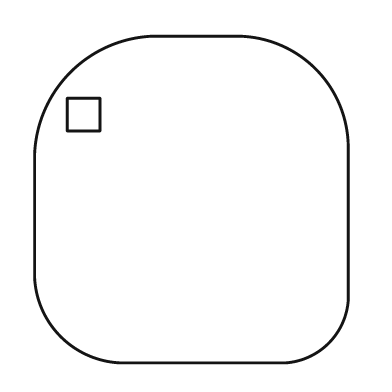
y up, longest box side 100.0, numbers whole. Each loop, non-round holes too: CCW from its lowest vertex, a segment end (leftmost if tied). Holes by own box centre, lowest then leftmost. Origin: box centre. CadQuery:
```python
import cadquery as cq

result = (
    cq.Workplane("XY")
    .moveTo(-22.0, -50.0)
    .lineTo(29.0, -50.0)
    .threePointArc((42.0, -44.0), (48.0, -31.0))
    .lineTo(48.0, 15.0)
    .threePointArc((38.0, 40.0), (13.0, 50.0))
    .lineTo(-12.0, 50.0)
    .threePointArc((-37.0, 39.0), (-48.0, 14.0))
    .lineTo(-48.0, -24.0)
    .threePointArc((-40.0, -42.0), (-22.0, -50.0))
    .close()
    .moveTo(-38.0, 21.0)
    .lineTo(-28.0, 21.0)
    .lineTo(-28.0, 31.0)
    .lineTo(-38.0, 31.0)
    .close()
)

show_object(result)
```